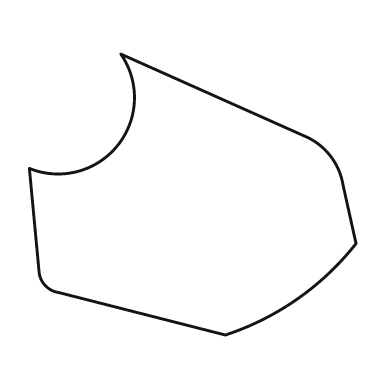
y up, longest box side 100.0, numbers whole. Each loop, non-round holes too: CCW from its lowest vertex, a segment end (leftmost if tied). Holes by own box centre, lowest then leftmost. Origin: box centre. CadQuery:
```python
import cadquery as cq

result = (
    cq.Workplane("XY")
    .moveTo(10.0, -43.0)
    .threePointArc((32.0, -32.0), (50.0, -15.0))
    .lineTo(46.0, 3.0)
    .threePointArc((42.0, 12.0), (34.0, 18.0))
    .lineTo(-22.0, 43.0)
    .threePointArc((-23.0, 15.0), (-50.0, 8.0))
    .lineTo(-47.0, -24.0)
    .threePointArc((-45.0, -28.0), (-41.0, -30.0))
    .close()
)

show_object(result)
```